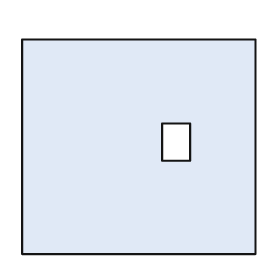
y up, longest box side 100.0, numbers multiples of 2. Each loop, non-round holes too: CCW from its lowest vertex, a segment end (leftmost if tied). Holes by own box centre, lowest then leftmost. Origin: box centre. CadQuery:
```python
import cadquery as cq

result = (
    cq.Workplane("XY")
    .moveTo(-50.0, -46.0)
    .lineTo(50.0, -46.0)
    .lineTo(50.0, 46.0)
    .lineTo(-50.0, 46.0)
    .close()
    .moveTo(10.0, -6.0)
    .lineTo(22.0, -6.0)
    .lineTo(22.0, 10.0)
    .lineTo(10.0, 10.0)
    .close()
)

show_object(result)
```